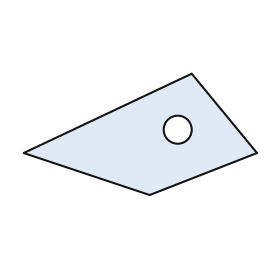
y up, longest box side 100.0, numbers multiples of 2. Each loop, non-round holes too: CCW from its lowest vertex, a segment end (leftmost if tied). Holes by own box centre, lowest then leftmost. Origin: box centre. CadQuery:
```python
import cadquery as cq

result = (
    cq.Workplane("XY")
    .moveTo(4.0, -26.0)
    .lineTo(50.0, -8.0)
    .lineTo(22.0, 26.0)
    .lineTo(-50.0, -8.0)
    .close()
    .moveTo(16.0, 2.0)
    .circle(6.0)
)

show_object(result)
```